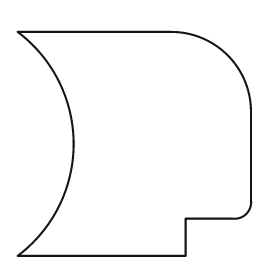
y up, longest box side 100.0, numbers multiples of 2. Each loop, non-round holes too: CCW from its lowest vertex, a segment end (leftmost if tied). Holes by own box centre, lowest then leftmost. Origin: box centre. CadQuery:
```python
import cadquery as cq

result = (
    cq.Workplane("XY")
    .moveTo(-50.0, -48.0)
    .lineTo(22.0, -48.0)
    .lineTo(22.0, -32.0)
    .lineTo(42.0, -32.0)
    .threePointArc((48.0, -30.0), (50.0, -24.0))
    .lineTo(50.0, 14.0)
    .threePointArc((40.0, 38.0), (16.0, 48.0))
    .lineTo(-50.0, 48.0)
    .threePointArc((-26.0, 0.0), (-50.0, -48.0))
    .close()
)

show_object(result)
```